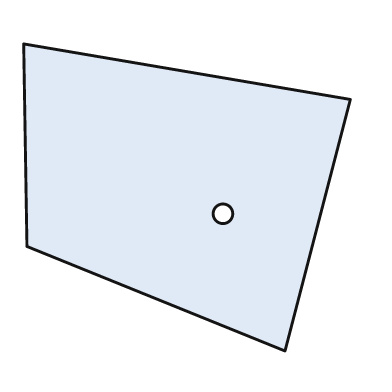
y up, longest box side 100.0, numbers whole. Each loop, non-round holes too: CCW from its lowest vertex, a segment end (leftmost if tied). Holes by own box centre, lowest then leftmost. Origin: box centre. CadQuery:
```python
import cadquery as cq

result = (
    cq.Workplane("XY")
    .moveTo(30.0, -47.0)
    .lineTo(50.0, 30.0)
    .lineTo(-50.0, 47.0)
    .lineTo(-49.0, -15.0)
    .close()
    .moveTo(11.0, -5.0)
    .circle(3.0)
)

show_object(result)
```